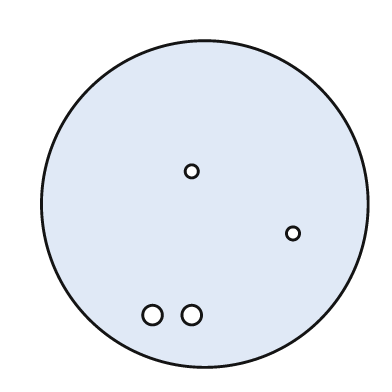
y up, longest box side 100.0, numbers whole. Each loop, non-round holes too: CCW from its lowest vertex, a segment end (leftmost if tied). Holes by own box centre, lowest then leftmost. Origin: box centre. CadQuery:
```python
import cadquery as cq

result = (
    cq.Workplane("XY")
    .moveTo(0.0, 0.0)
    .circle(50.0)
    .moveTo(-16.0, -34.0)
    .circle(3.0)
    .moveTo(-4.0, -34.0)
    .circle(3.0)
    .moveTo(27.0, -9.0)
    .circle(2.0)
    .moveTo(-4.0, 10.0)
    .circle(2.0)
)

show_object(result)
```